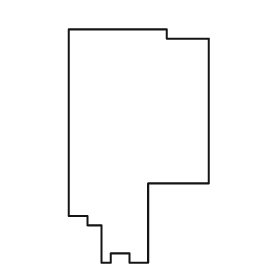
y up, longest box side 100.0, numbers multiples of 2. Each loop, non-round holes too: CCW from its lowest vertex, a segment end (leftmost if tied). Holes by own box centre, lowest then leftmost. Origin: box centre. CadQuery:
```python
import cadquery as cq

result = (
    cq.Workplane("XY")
    .moveTo(-16.0, -50.0)
    .lineTo(-12.0, -50.0)
    .lineTo(-12.0, -46.0)
    .lineTo(-4.0, -46.0)
    .lineTo(-4.0, -50.0)
    .lineTo(4.0, -50.0)
    .lineTo(4.0, -16.0)
    .lineTo(30.0, -16.0)
    .lineTo(30.0, 46.0)
    .lineTo(12.0, 46.0)
    .lineTo(12.0, 50.0)
    .lineTo(-30.0, 50.0)
    .lineTo(-30.0, -30.0)
    .lineTo(-22.0, -30.0)
    .lineTo(-22.0, -34.0)
    .lineTo(-16.0, -34.0)
    .close()
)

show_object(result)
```